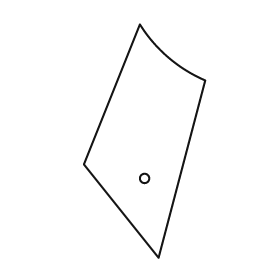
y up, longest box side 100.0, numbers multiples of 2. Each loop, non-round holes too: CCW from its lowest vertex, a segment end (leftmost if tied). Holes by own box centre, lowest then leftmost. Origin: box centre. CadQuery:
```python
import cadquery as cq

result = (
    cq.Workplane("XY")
    .moveTo(6.0, -50.0)
    .lineTo(26.0, 26.0)
    .threePointArc((10.0, 36.0), (-2.0, 50.0))
    .lineTo(-26.0, -10.0)
    .close()
    .moveTo(0.0, -16.0)
    .circle(2.0)
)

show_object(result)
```